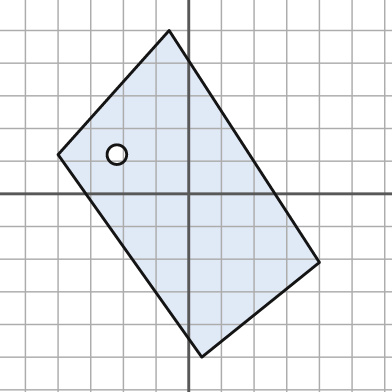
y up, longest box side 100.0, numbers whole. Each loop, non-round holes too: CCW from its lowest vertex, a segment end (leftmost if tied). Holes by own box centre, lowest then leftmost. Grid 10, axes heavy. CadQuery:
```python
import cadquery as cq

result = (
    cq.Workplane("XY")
    .moveTo(4.0, -50.0)
    .lineTo(40.0, -21.0)
    .lineTo(-6.0, 50.0)
    .lineTo(-40.0, 12.0)
    .close()
    .moveTo(-22.0, 12.0)
    .circle(3.0)
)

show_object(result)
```